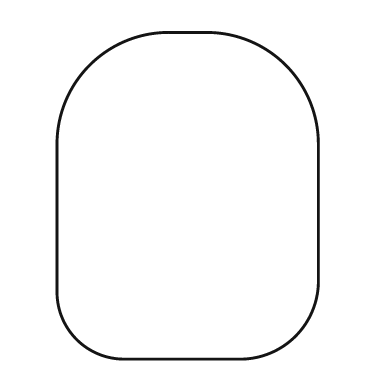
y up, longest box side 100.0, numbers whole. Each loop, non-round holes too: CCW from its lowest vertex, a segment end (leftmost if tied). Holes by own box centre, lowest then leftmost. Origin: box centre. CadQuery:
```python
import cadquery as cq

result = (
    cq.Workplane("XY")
    .moveTo(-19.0, -50.0)
    .lineTo(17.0, -50.0)
    .threePointArc((33.0, -43.0), (40.0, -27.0))
    .lineTo(40.0, 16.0)
    .threePointArc((30.0, 40.0), (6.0, 50.0))
    .lineTo(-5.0, 50.0)
    .threePointArc((-30.0, 40.0), (-40.0, 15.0))
    .lineTo(-40.0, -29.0)
    .threePointArc((-34.0, -44.0), (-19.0, -50.0))
    .close()
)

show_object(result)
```